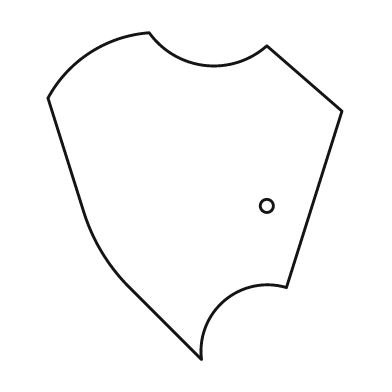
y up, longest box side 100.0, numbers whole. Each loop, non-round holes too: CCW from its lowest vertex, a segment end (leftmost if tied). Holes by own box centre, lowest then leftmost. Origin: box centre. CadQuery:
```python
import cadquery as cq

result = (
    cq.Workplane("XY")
    .moveTo(2.0, -50.0)
    .threePointArc((9.0, -32.0), (28.0, -28.0))
    .lineTo(45.0, 26.0)
    .lineTo(22.0, 46.0)
    .threePointArc((3.0, 40.0), (-14.0, 50.0))
    .threePointArc((-32.0, 44.0), (-45.0, 30.0))
    .lineTo(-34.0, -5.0)
    .threePointArc((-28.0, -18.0), (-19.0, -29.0))
    .close()
    .moveTo(22.0, -3.0)
    .circle(2.0)
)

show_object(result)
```